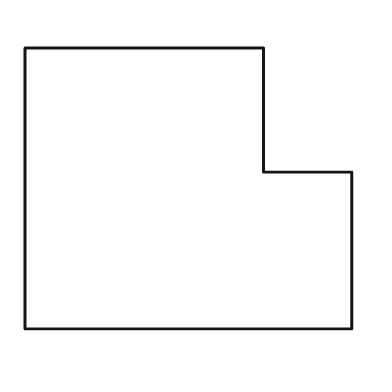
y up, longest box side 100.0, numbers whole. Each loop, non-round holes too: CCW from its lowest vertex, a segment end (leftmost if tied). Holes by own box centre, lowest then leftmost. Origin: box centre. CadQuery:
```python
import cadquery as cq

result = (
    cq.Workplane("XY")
    .moveTo(-50.0, -43.0)
    .lineTo(50.0, -43.0)
    .lineTo(50.0, 5.0)
    .lineTo(23.0, 5.0)
    .lineTo(23.0, 43.0)
    .lineTo(-50.0, 43.0)
    .close()
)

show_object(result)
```